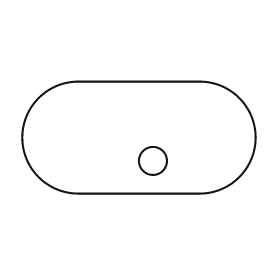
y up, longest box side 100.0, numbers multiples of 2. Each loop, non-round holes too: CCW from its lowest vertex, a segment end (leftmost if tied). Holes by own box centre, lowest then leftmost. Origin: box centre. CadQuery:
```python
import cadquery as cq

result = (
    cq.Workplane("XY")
    .moveTo(-26.0, -24.0)
    .lineTo(26.0, -24.0)
    .threePointArc((50.0, 0.0), (26.0, 24.0))
    .lineTo(-26.0, 24.0)
    .threePointArc((-50.0, 0.0), (-26.0, -24.0))
    .close()
    .moveTo(6.0, -10.0)
    .circle(6.0)
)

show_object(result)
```